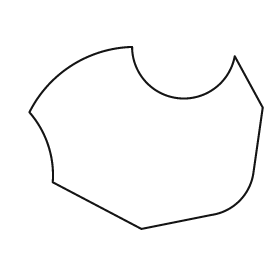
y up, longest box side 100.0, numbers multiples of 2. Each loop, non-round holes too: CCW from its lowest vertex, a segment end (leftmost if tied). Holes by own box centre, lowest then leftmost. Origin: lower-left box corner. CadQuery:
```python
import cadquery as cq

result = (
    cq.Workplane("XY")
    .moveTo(48.0, 0.0)
    .lineTo(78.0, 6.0)
    .threePointArc((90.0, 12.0), (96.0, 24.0))
    .lineTo(100.0, 52.0)
    .lineTo(88.0, 74.0)
    .threePointArc((64.0, 56.0), (44.0, 78.0))
    .threePointArc((18.0, 70.0), (0.0, 50.0))
    .threePointArc((8.0, 36.0), (10.0, 20.0))
    .close()
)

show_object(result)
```